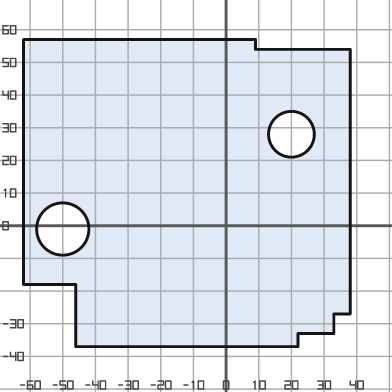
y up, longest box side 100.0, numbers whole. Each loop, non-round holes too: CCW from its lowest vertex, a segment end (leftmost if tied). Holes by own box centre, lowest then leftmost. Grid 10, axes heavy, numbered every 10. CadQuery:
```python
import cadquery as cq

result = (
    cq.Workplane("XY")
    .moveTo(-46.0, -37.0)
    .lineTo(22.0, -37.0)
    .lineTo(22.0, -33.0)
    .lineTo(33.0, -33.0)
    .lineTo(33.0, -27.0)
    .lineTo(38.0, -27.0)
    .lineTo(38.0, 54.0)
    .lineTo(9.0, 54.0)
    .lineTo(9.0, 57.0)
    .lineTo(-62.0, 57.0)
    .lineTo(-62.0, -18.0)
    .lineTo(-46.0, -18.0)
    .close()
    .moveTo(-50.0, -1.0)
    .circle(8.0)
    .moveTo(20.0, 28.0)
    .circle(7.0)
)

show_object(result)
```